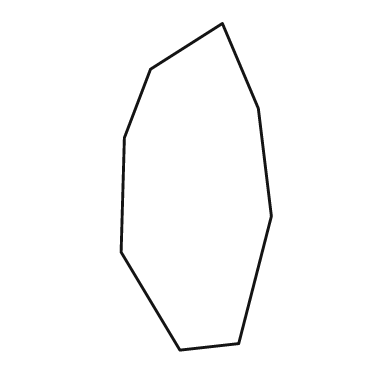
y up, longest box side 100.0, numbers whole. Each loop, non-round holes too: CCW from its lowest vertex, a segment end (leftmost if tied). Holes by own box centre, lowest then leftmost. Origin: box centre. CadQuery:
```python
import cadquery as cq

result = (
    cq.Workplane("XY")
    .moveTo(-5.0, -50.0)
    .lineTo(13.0, -48.0)
    .lineTo(23.0, -9.0)
    .lineTo(19.0, 24.0)
    .lineTo(8.0, 50.0)
    .lineTo(-14.0, 36.0)
    .lineTo(-22.0, 15.0)
    .lineTo(-23.0, -20.0)
    .close()
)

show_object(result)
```